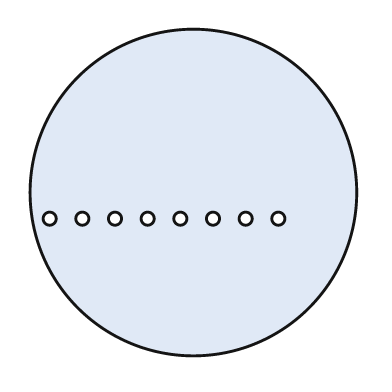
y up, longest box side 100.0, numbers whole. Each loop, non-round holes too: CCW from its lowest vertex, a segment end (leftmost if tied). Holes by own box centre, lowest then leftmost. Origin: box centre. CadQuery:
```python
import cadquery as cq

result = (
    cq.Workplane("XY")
    .moveTo(0.0, 0.0)
    .circle(50.0)
    .moveTo(-44.0, -8.0)
    .circle(2.0)
    .moveTo(-34.0, -8.0)
    .circle(2.0)
    .moveTo(-24.0, -8.0)
    .circle(2.0)
    .moveTo(-14.0, -8.0)
    .circle(2.0)
    .moveTo(-4.0, -8.0)
    .circle(2.0)
    .moveTo(6.0, -8.0)
    .circle(2.0)
    .moveTo(16.0, -8.0)
    .circle(2.0)
    .moveTo(26.0, -8.0)
    .circle(2.0)
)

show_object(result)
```